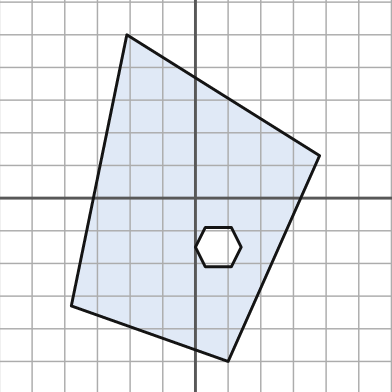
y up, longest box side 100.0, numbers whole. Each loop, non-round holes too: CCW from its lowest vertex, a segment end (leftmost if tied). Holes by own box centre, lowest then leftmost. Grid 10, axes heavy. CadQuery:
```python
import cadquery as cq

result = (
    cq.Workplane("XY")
    .moveTo(10.0, -50.0)
    .lineTo(38.0, 13.0)
    .lineTo(-21.0, 50.0)
    .lineTo(-38.0, -33.0)
    .close()
    .moveTo(3.0, -21.0)
    .lineTo(11.0, -21.0)
    .lineTo(14.0, -15.0)
    .lineTo(11.0, -9.0)
    .lineTo(3.0, -9.0)
    .lineTo(0.0, -15.0)
    .close()
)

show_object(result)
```